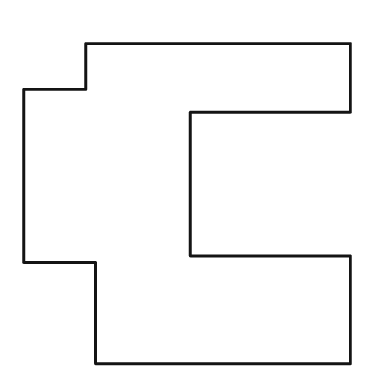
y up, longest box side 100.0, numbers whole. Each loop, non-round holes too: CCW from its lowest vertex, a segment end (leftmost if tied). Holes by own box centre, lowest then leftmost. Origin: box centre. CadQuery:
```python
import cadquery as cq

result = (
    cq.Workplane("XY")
    .moveTo(-28.0, -49.0)
    .lineTo(50.0, -49.0)
    .lineTo(50.0, -16.0)
    .lineTo(1.0, -16.0)
    .lineTo(1.0, 28.0)
    .lineTo(50.0, 28.0)
    .lineTo(50.0, 49.0)
    .lineTo(-31.0, 49.0)
    .lineTo(-31.0, 35.0)
    .lineTo(-50.0, 35.0)
    .lineTo(-50.0, -18.0)
    .lineTo(-28.0, -18.0)
    .close()
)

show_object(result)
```